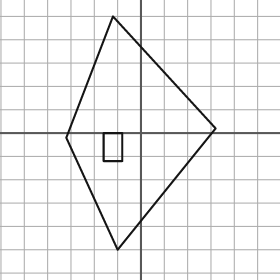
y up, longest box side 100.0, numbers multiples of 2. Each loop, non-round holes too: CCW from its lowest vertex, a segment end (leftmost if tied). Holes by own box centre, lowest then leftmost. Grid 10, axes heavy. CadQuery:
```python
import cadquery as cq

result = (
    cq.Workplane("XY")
    .moveTo(-10.0, -50.0)
    .lineTo(32.0, 2.0)
    .lineTo(-12.0, 50.0)
    .lineTo(-32.0, -2.0)
    .close()
    .moveTo(-16.0, -12.0)
    .lineTo(-8.0, -12.0)
    .lineTo(-8.0, 0.0)
    .lineTo(-16.0, 0.0)
    .close()
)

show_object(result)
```